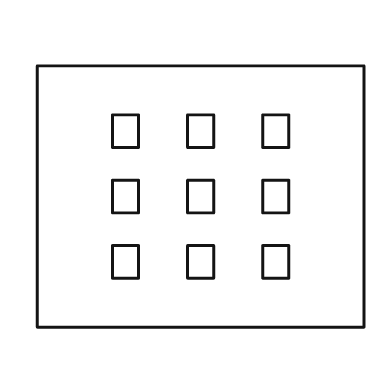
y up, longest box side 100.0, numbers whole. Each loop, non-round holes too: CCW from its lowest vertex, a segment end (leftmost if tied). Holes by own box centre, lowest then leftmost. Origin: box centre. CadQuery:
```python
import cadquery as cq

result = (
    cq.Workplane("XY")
    .moveTo(-50.0, -40.0)
    .lineTo(50.0, -40.0)
    .lineTo(50.0, 40.0)
    .lineTo(-50.0, 40.0)
    .close()
    .moveTo(-27.0, -25.0)
    .lineTo(-19.0, -25.0)
    .lineTo(-19.0, -15.0)
    .lineTo(-27.0, -15.0)
    .close()
    .moveTo(-4.0, -25.0)
    .lineTo(4.0, -25.0)
    .lineTo(4.0, -15.0)
    .lineTo(-4.0, -15.0)
    .close()
    .moveTo(19.0, -25.0)
    .lineTo(27.0, -25.0)
    .lineTo(27.0, -15.0)
    .lineTo(19.0, -15.0)
    .close()
    .moveTo(-27.0, -5.0)
    .lineTo(-19.0, -5.0)
    .lineTo(-19.0, 5.0)
    .lineTo(-27.0, 5.0)
    .close()
    .moveTo(-4.0, -5.0)
    .lineTo(4.0, -5.0)
    .lineTo(4.0, 5.0)
    .lineTo(-4.0, 5.0)
    .close()
    .moveTo(19.0, -5.0)
    .lineTo(27.0, -5.0)
    .lineTo(27.0, 5.0)
    .lineTo(19.0, 5.0)
    .close()
    .moveTo(-27.0, 15.0)
    .lineTo(-19.0, 15.0)
    .lineTo(-19.0, 25.0)
    .lineTo(-27.0, 25.0)
    .close()
    .moveTo(-4.0, 15.0)
    .lineTo(4.0, 15.0)
    .lineTo(4.0, 25.0)
    .lineTo(-4.0, 25.0)
    .close()
    .moveTo(19.0, 15.0)
    .lineTo(27.0, 15.0)
    .lineTo(27.0, 25.0)
    .lineTo(19.0, 25.0)
    .close()
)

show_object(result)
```